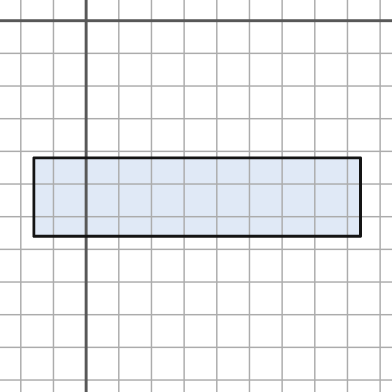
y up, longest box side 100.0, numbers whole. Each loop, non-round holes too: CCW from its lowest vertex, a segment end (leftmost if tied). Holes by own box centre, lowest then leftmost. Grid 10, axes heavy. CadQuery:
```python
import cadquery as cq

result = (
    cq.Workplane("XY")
    .moveTo(-16.0, -66.0)
    .lineTo(84.0, -66.0)
    .lineTo(84.0, -42.0)
    .lineTo(-16.0, -42.0)
    .close()
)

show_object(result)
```